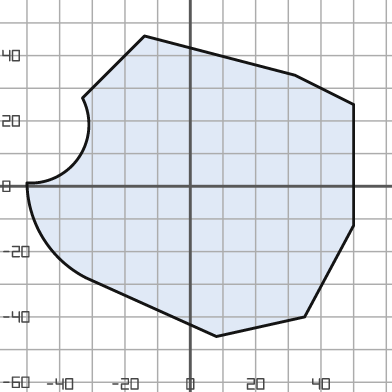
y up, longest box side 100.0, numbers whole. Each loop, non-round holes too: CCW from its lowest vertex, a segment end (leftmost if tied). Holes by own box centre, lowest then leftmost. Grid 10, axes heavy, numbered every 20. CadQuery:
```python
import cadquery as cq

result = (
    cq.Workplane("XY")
    .moveTo(8.0, -46.0)
    .lineTo(35.0, -40.0)
    .lineTo(50.0, -12.0)
    .lineTo(50.0, 25.0)
    .lineTo(32.0, 34.0)
    .lineTo(-14.0, 46.0)
    .lineTo(-33.0, 27.0)
    .threePointArc((-34.0, 9.0), (-50.0, 1.0))
    .threePointArc((-45.0, -16.0), (-32.0, -28.0))
    .close()
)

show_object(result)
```